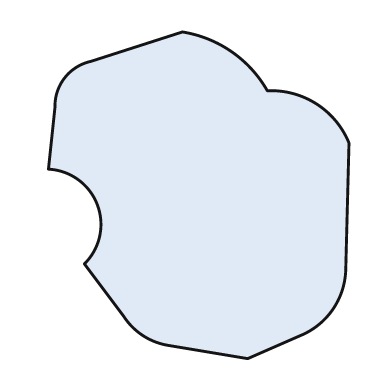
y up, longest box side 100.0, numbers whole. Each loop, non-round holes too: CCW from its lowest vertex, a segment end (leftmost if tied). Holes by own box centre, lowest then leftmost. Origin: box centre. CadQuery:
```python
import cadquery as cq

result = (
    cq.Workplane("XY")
    .moveTo(15.0, -50.0)
    .lineTo(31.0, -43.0)
    .threePointArc((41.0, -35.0), (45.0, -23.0))
    .lineTo(46.0, 16.0)
    .threePointArc((36.0, 28.0), (21.0, 32.0))
    .threePointArc((10.0, 44.0), (-5.0, 50.0))
    .lineTo(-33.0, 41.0)
    .threePointArc((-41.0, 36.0), (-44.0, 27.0))
    .lineTo(-46.0, 8.0)
    .threePointArc((-31.0, -3.0), (-35.0, -21.0))
    .lineTo(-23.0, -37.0)
    .threePointArc((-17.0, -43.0), (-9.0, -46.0))
    .close()
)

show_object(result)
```